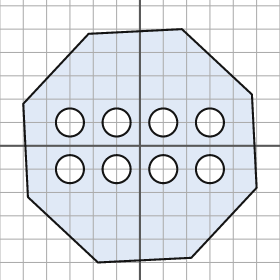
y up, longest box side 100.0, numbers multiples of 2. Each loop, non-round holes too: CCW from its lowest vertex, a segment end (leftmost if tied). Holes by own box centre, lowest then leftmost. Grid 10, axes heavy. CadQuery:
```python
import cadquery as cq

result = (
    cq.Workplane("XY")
    .moveTo(-18.0, -50.0)
    .lineTo(22.0, -48.0)
    .lineTo(50.0, -18.0)
    .lineTo(48.0, 22.0)
    .lineTo(18.0, 50.0)
    .lineTo(-22.0, 48.0)
    .lineTo(-50.0, 18.0)
    .lineTo(-48.0, -22.0)
    .close()
    .moveTo(-30.0, -10.0)
    .circle(6.0)
    .moveTo(-10.0, -10.0)
    .circle(6.0)
    .moveTo(10.0, -10.0)
    .circle(6.0)
    .moveTo(30.0, -10.0)
    .circle(6.0)
    .moveTo(-30.0, 10.0)
    .circle(6.0)
    .moveTo(-10.0, 10.0)
    .circle(6.0)
    .moveTo(10.0, 10.0)
    .circle(6.0)
    .moveTo(30.0, 10.0)
    .circle(6.0)
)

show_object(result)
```